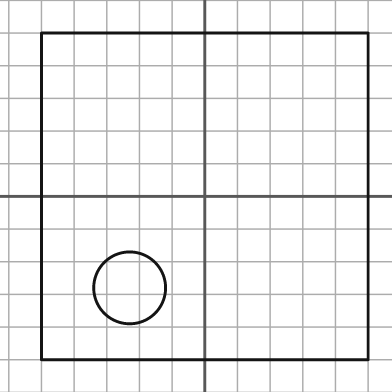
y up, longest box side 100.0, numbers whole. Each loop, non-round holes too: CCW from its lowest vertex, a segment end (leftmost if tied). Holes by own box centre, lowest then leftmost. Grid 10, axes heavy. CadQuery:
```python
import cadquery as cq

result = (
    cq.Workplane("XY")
    .moveTo(-50.0, -50.0)
    .lineTo(50.0, -50.0)
    .lineTo(50.0, 50.0)
    .lineTo(-50.0, 50.0)
    .close()
    .moveTo(-23.0, -28.0)
    .circle(11.0)
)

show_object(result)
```